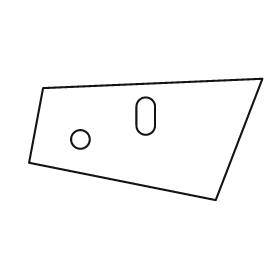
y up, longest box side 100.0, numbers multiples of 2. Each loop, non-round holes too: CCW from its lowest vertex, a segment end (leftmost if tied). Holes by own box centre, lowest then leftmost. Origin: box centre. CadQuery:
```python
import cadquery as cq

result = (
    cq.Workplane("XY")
    .moveTo(30.0, -26.0)
    .lineTo(50.0, 26.0)
    .lineTo(-44.0, 22.0)
    .lineTo(-50.0, -10.0)
    .close()
    .moveTo(-28.0, 0.0)
    .circle(4.0)
    .moveTo(-4.0, 6.0)
    .threePointArc((0.0, 2.0), (4.0, 6.0))
    .lineTo(4.0, 14.0)
    .threePointArc((0.0, 18.0), (-4.0, 14.0))
    .close()
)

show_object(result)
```